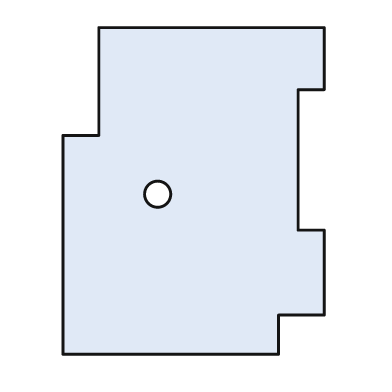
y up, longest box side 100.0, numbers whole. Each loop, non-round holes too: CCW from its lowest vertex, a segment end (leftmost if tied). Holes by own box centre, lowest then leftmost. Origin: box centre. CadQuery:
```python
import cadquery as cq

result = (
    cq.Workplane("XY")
    .moveTo(-40.0, -50.0)
    .lineTo(26.0, -50.0)
    .lineTo(26.0, -38.0)
    .lineTo(40.0, -38.0)
    .lineTo(40.0, -12.0)
    .lineTo(32.0, -12.0)
    .lineTo(32.0, 31.0)
    .lineTo(40.0, 31.0)
    .lineTo(40.0, 50.0)
    .lineTo(-29.0, 50.0)
    .lineTo(-29.0, 17.0)
    .lineTo(-40.0, 17.0)
    .close()
    .moveTo(-11.0, -1.0)
    .circle(4.0)
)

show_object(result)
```